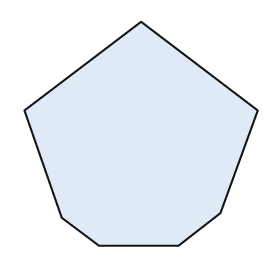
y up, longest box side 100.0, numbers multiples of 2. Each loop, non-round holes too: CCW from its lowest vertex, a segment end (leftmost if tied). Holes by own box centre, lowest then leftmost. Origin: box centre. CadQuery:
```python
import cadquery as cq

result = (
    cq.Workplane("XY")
    .moveTo(-18.0, -48.0)
    .lineTo(16.0, -48.0)
    .lineTo(34.0, -34.0)
    .lineTo(50.0, 10.0)
    .lineTo(0.0, 48.0)
    .lineTo(-50.0, 10.0)
    .lineTo(-34.0, -36.0)
    .close()
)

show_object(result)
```